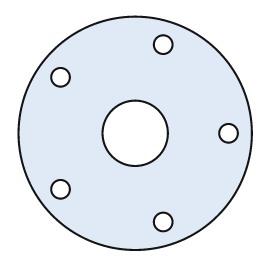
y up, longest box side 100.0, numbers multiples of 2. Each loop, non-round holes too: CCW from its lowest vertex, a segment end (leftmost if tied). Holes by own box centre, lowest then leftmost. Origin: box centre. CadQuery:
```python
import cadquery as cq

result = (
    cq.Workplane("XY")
    .moveTo(0.0, 0.0)
    .circle(50.0)
    .moveTo(12.0, -38.0)
    .circle(4.0)
    .moveTo(-32.0, -24.0)
    .circle(4.0)
    .moveTo(0.0, 0.0)
    .circle(14.0)
    .moveTo(40.0, 0.0)
    .circle(4.0)
    .moveTo(-32.0, 24.0)
    .circle(4.0)
    .moveTo(12.0, 38.0)
    .circle(4.0)
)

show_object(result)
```